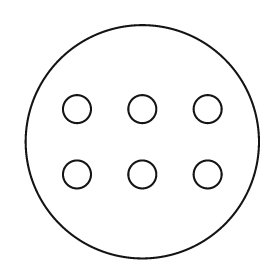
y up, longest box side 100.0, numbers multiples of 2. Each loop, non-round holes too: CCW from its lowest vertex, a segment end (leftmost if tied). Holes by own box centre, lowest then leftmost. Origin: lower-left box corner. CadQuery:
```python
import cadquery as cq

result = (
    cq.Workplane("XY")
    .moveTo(50.0, 50.0)
    .circle(50.0)
    .moveTo(22.0, 36.0)
    .circle(6.0)
    .moveTo(50.0, 36.0)
    .circle(6.0)
    .moveTo(78.0, 36.0)
    .circle(6.0)
    .moveTo(22.0, 64.0)
    .circle(6.0)
    .moveTo(50.0, 64.0)
    .circle(6.0)
    .moveTo(78.0, 64.0)
    .circle(6.0)
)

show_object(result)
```